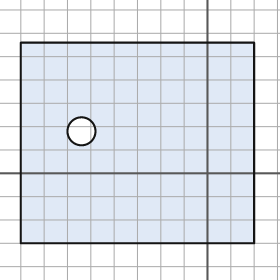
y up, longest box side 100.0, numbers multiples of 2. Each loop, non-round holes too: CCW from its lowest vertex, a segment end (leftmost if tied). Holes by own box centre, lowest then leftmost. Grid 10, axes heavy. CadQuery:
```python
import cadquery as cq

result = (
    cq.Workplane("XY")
    .moveTo(-80.0, -30.0)
    .lineTo(20.0, -30.0)
    .lineTo(20.0, 56.0)
    .lineTo(-80.0, 56.0)
    .close()
    .moveTo(-54.0, 18.0)
    .circle(6.0)
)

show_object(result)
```